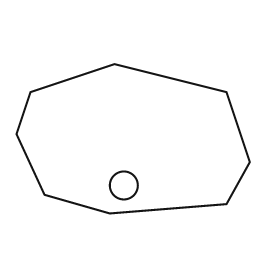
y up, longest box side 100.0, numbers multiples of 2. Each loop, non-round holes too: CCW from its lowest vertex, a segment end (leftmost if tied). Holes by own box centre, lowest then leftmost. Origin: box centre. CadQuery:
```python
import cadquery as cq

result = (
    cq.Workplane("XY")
    .moveTo(-10.0, -32.0)
    .lineTo(40.0, -28.0)
    .lineTo(50.0, -10.0)
    .lineTo(40.0, 20.0)
    .lineTo(-8.0, 32.0)
    .lineTo(-44.0, 20.0)
    .lineTo(-50.0, 2.0)
    .lineTo(-38.0, -24.0)
    .close()
    .moveTo(-4.0, -20.0)
    .circle(6.0)
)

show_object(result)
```